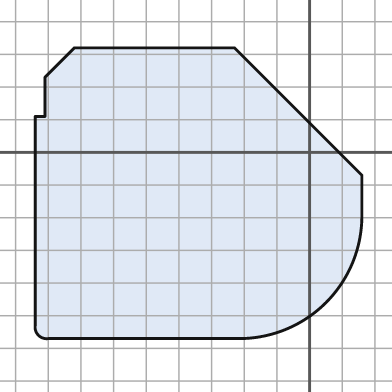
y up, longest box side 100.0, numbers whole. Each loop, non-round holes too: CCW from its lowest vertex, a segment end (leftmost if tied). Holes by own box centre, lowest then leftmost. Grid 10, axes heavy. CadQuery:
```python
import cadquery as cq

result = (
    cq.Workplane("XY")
    .moveTo(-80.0, -57.0)
    .lineTo(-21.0, -57.0)
    .threePointArc((5.0, -46.0), (16.0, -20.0))
    .lineTo(16.0, -7.0)
    .lineTo(-23.0, 32.0)
    .lineTo(-72.0, 32.0)
    .lineTo(-81.0, 23.0)
    .lineTo(-81.0, 11.0)
    .lineTo(-84.0, 11.0)
    .lineTo(-84.0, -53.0)
    .threePointArc((-83.0, -56.0), (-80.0, -57.0))
    .close()
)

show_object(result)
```